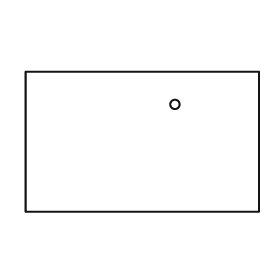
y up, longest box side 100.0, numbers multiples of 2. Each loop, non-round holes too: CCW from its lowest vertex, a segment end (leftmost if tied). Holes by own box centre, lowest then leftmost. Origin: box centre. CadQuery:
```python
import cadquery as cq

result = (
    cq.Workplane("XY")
    .moveTo(-50.0, -30.0)
    .lineTo(50.0, -30.0)
    .lineTo(50.0, 30.0)
    .lineTo(-50.0, 30.0)
    .close()
    .moveTo(14.0, 16.0)
    .circle(2.0)
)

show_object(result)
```